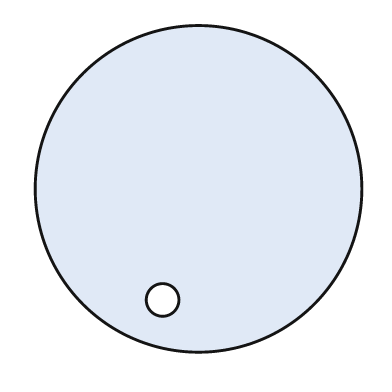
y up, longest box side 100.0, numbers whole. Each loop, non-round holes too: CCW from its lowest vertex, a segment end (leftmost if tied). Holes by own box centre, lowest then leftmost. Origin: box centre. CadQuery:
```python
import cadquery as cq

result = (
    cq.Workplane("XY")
    .moveTo(0.0, 0.0)
    .circle(50.0)
    .moveTo(-11.0, -34.0)
    .circle(5.0)
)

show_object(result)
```